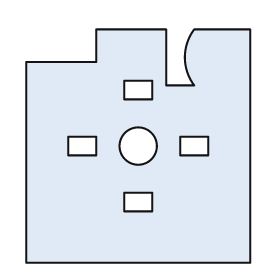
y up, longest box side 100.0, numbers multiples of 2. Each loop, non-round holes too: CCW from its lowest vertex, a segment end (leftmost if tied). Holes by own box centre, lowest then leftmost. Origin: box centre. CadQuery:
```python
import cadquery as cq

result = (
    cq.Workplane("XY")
    .moveTo(-48.0, -50.0)
    .lineTo(48.0, -50.0)
    .lineTo(48.0, 50.0)
    .lineTo(24.0, 50.0)
    .threePointArc((20.0, 38.0), (24.0, 26.0))
    .lineTo(12.0, 26.0)
    .lineTo(12.0, 50.0)
    .lineTo(-18.0, 50.0)
    .lineTo(-18.0, 36.0)
    .lineTo(-48.0, 36.0)
    .close()
    .moveTo(-6.0, -28.0)
    .lineTo(6.0, -28.0)
    .lineTo(6.0, -20.0)
    .lineTo(-6.0, -20.0)
    .close()
    .moveTo(-30.0, -4.0)
    .lineTo(-18.0, -4.0)
    .lineTo(-18.0, 4.0)
    .lineTo(-30.0, 4.0)
    .close()
    .moveTo(0.0, 0.0)
    .circle(8.0)
    .moveTo(18.0, -4.0)
    .lineTo(30.0, -4.0)
    .lineTo(30.0, 4.0)
    .lineTo(18.0, 4.0)
    .close()
    .moveTo(-6.0, 20.0)
    .lineTo(6.0, 20.0)
    .lineTo(6.0, 28.0)
    .lineTo(-6.0, 28.0)
    .close()
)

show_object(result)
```